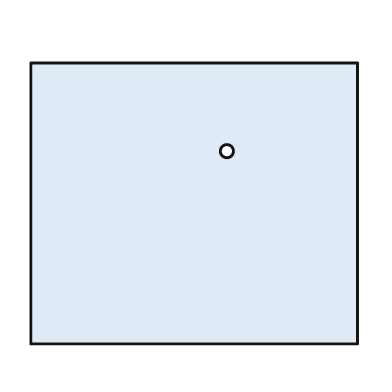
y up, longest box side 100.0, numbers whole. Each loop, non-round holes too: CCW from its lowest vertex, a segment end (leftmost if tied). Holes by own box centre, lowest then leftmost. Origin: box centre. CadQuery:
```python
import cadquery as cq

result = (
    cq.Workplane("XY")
    .moveTo(-50.0, -43.0)
    .lineTo(50.0, -43.0)
    .lineTo(50.0, 43.0)
    .lineTo(-50.0, 43.0)
    .close()
    .moveTo(10.0, 16.0)
    .circle(2.0)
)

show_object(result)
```